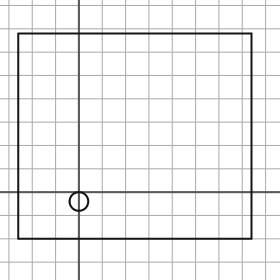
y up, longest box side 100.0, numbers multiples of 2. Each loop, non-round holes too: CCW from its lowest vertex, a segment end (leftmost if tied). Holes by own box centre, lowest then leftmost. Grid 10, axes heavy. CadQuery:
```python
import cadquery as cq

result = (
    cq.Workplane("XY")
    .moveTo(-26.0, -20.0)
    .lineTo(74.0, -20.0)
    .lineTo(74.0, 68.0)
    .lineTo(-26.0, 68.0)
    .close()
    .moveTo(0.0, -4.0)
    .circle(4.0)
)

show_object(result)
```